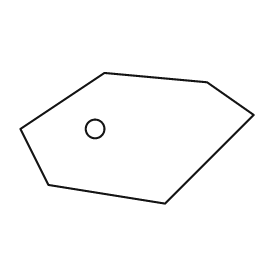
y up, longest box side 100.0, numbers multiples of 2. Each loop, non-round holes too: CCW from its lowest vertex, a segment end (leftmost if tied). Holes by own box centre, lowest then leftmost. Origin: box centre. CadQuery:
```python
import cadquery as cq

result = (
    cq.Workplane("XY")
    .moveTo(12.0, -28.0)
    .lineTo(50.0, 10.0)
    .lineTo(30.0, 24.0)
    .lineTo(-14.0, 28.0)
    .lineTo(-50.0, 4.0)
    .lineTo(-38.0, -20.0)
    .close()
    .moveTo(-18.0, 4.0)
    .circle(4.0)
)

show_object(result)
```